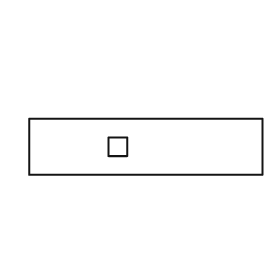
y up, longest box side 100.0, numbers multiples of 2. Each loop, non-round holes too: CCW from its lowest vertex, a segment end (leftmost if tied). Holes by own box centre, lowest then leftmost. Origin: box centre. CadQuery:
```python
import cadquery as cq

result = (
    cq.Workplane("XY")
    .moveTo(-50.0, -12.0)
    .lineTo(50.0, -12.0)
    .lineTo(50.0, 12.0)
    .lineTo(-50.0, 12.0)
    .close()
    .moveTo(-16.0, -4.0)
    .lineTo(-8.0, -4.0)
    .lineTo(-8.0, 4.0)
    .lineTo(-16.0, 4.0)
    .close()
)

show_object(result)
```